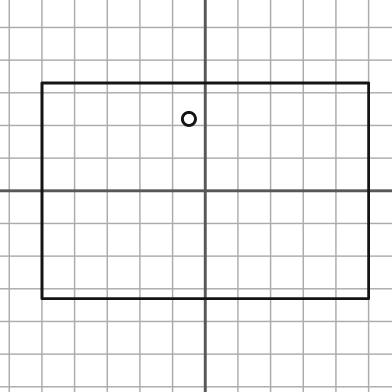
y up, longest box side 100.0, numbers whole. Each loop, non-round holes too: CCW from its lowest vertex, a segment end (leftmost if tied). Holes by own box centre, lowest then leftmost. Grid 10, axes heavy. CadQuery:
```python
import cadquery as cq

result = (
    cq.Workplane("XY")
    .moveTo(-50.0, -33.0)
    .lineTo(50.0, -33.0)
    .lineTo(50.0, 33.0)
    .lineTo(-50.0, 33.0)
    .close()
    .moveTo(-5.0, 22.0)
    .circle(2.0)
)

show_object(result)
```